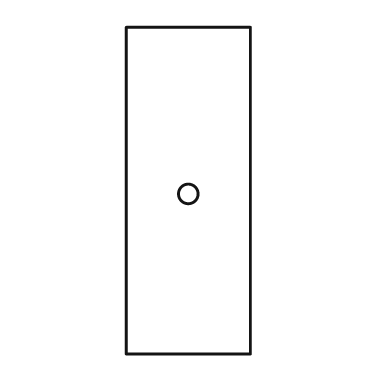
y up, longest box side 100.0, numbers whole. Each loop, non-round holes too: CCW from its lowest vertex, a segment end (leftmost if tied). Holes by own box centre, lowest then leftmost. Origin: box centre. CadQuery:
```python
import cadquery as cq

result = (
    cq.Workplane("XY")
    .moveTo(-19.0, -50.0)
    .lineTo(19.0, -50.0)
    .lineTo(19.0, 50.0)
    .lineTo(-19.0, 50.0)
    .close()
    .moveTo(0.0, -1.0)
    .circle(3.0)
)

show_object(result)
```